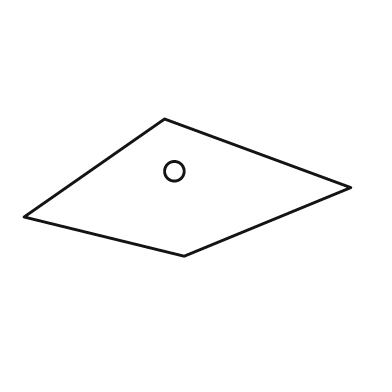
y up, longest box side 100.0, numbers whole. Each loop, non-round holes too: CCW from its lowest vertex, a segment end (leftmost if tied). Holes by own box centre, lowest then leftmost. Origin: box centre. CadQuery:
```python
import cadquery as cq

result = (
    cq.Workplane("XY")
    .moveTo(-1.0, -21.0)
    .lineTo(50.0, 0.0)
    .lineTo(-7.0, 21.0)
    .lineTo(-50.0, -9.0)
    .close()
    .moveTo(-4.0, 5.0)
    .circle(3.0)
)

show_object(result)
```